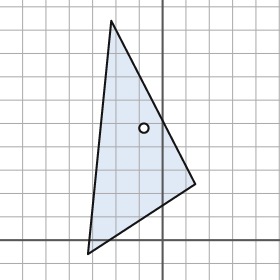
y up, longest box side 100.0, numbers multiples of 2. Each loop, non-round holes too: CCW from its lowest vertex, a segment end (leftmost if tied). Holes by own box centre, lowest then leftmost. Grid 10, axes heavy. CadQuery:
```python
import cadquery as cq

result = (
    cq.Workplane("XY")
    .moveTo(-32.0, -6.0)
    .lineTo(14.0, 24.0)
    .lineTo(-22.0, 94.0)
    .close()
    .moveTo(-8.0, 48.0)
    .circle(2.0)
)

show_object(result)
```